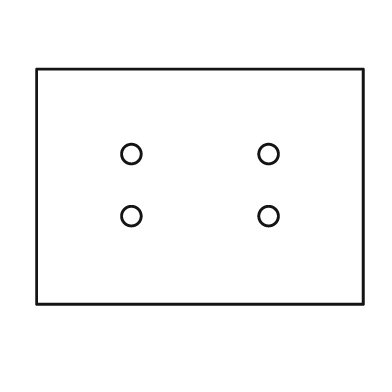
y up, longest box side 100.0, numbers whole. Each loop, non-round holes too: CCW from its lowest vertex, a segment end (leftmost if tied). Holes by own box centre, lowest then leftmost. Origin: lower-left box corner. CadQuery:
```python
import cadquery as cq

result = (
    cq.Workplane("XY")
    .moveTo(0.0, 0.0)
    .lineTo(100.0, 0.0)
    .lineTo(100.0, 72.0)
    .lineTo(0.0, 72.0)
    .close()
    .moveTo(29.0, 27.0)
    .circle(3.0)
    .moveTo(71.0, 27.0)
    .circle(3.0)
    .moveTo(29.0, 46.0)
    .circle(3.0)
    .moveTo(71.0, 46.0)
    .circle(3.0)
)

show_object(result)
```